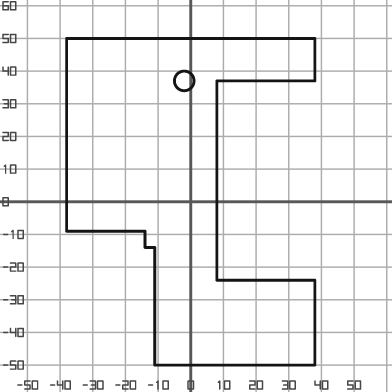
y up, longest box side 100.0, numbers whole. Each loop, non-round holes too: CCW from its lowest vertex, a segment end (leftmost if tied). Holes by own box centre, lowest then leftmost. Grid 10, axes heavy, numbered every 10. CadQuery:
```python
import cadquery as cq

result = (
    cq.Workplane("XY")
    .moveTo(-11.0, -50.0)
    .lineTo(38.0, -50.0)
    .lineTo(38.0, -24.0)
    .lineTo(8.0, -24.0)
    .lineTo(8.0, 37.0)
    .lineTo(38.0, 37.0)
    .lineTo(38.0, 50.0)
    .lineTo(-38.0, 50.0)
    .lineTo(-38.0, -9.0)
    .lineTo(-14.0, -9.0)
    .lineTo(-14.0, -14.0)
    .lineTo(-11.0, -14.0)
    .close()
    .moveTo(-2.0, 37.0)
    .circle(3.0)
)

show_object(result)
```